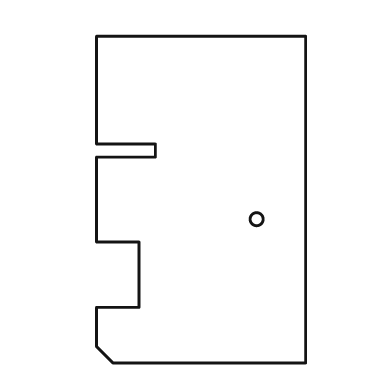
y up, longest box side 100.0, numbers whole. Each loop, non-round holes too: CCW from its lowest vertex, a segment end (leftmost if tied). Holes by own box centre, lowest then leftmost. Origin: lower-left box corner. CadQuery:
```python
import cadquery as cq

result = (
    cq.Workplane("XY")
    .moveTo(5.0, 0.0)
    .lineTo(64.0, 0.0)
    .lineTo(64.0, 100.0)
    .lineTo(0.0, 100.0)
    .lineTo(0.0, 67.0)
    .lineTo(18.0, 67.0)
    .lineTo(18.0, 63.0)
    .lineTo(0.0, 63.0)
    .lineTo(0.0, 37.0)
    .lineTo(13.0, 37.0)
    .lineTo(13.0, 17.0)
    .lineTo(0.0, 17.0)
    .lineTo(0.0, 5.0)
    .close()
    .moveTo(49.0, 44.0)
    .circle(2.0)
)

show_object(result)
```